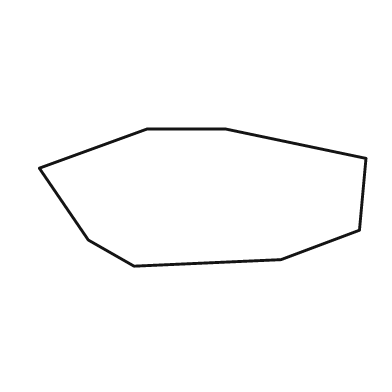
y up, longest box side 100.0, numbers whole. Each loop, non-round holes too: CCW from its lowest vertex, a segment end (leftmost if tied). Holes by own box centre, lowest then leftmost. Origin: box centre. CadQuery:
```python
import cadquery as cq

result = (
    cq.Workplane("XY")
    .moveTo(-21.0, -21.0)
    .lineTo(24.0, -19.0)
    .lineTo(48.0, -10.0)
    .lineTo(50.0, 12.0)
    .lineTo(7.0, 21.0)
    .lineTo(-17.0, 21.0)
    .lineTo(-50.0, 9.0)
    .lineTo(-35.0, -13.0)
    .close()
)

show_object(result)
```